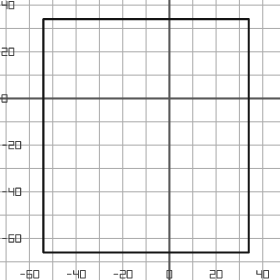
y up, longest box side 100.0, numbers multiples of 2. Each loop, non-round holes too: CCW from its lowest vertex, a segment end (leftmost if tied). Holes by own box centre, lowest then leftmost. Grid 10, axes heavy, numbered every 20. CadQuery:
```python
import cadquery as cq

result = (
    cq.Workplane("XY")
    .moveTo(-54.0, -66.0)
    .lineTo(34.0, -66.0)
    .lineTo(34.0, 34.0)
    .lineTo(-54.0, 34.0)
    .close()
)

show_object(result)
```